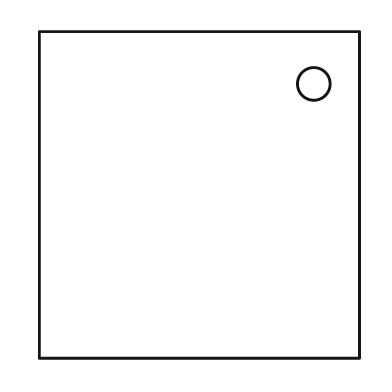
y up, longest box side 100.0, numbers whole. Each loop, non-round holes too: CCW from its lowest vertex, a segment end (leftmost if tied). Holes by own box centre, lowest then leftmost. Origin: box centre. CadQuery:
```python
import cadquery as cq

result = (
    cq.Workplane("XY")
    .moveTo(-49.0, -50.0)
    .lineTo(49.0, -50.0)
    .lineTo(49.0, 50.0)
    .lineTo(-49.0, 50.0)
    .close()
    .moveTo(35.0, 34.0)
    .circle(5.0)
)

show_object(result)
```